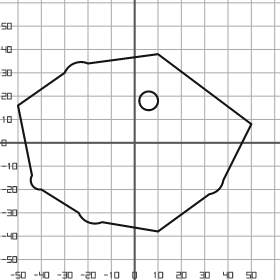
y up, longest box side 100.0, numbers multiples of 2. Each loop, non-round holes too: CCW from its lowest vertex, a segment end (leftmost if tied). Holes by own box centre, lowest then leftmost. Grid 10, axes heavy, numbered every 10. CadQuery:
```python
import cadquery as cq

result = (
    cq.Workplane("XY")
    .moveTo(10.0, -38.0)
    .lineTo(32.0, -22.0)
    .threePointArc((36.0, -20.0), (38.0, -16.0))
    .lineTo(50.0, 8.0)
    .lineTo(10.0, 38.0)
    .lineTo(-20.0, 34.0)
    .threePointArc((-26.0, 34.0), (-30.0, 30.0))
    .lineTo(-50.0, 16.0)
    .lineTo(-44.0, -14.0)
    .threePointArc((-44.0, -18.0), (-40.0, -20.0))
    .lineTo(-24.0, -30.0)
    .threePointArc((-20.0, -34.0), (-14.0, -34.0))
    .close()
    .moveTo(6.0, 18.0)
    .circle(4.0)
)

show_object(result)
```